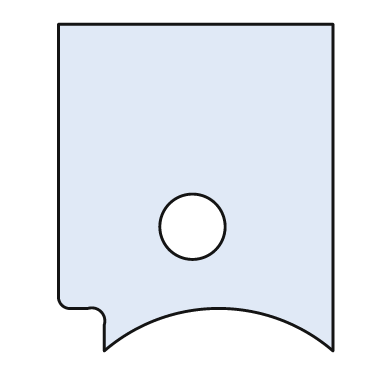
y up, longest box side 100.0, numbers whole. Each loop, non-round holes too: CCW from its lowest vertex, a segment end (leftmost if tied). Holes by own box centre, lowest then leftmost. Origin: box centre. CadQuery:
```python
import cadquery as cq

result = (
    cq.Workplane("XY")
    .moveTo(-28.0, -50.0)
    .threePointArc((7.0, -37.0), (42.0, -50.0))
    .lineTo(42.0, 50.0)
    .lineTo(-42.0, 50.0)
    .lineTo(-42.0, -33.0)
    .threePointArc((-41.0, -36.0), (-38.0, -37.0))
    .lineTo(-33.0, -37.0)
    .threePointArc((-29.0, -38.0), (-28.0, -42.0))
    .close()
    .moveTo(-1.0, -12.0)
    .circle(10.0)
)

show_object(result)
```